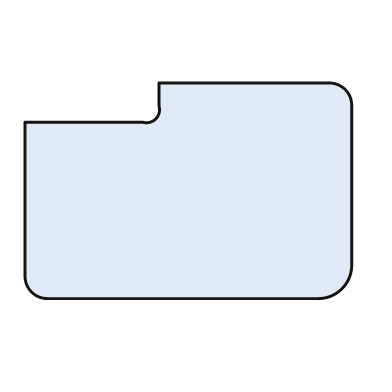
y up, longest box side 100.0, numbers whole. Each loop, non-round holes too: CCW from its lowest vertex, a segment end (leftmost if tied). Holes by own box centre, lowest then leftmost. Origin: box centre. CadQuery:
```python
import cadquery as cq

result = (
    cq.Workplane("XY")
    .moveTo(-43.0, -33.0)
    .lineTo(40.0, -33.0)
    .threePointArc((47.0, -30.0), (50.0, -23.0))
    .lineTo(50.0, 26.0)
    .threePointArc((48.0, 31.0), (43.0, 33.0))
    .lineTo(-9.0, 33.0)
    .lineTo(-9.0, 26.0)
    .threePointArc((-10.0, 22.0), (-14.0, 21.0))
    .lineTo(-50.0, 21.0)
    .lineTo(-50.0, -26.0)
    .threePointArc((-48.0, -31.0), (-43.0, -33.0))
    .close()
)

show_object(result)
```